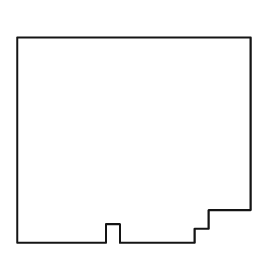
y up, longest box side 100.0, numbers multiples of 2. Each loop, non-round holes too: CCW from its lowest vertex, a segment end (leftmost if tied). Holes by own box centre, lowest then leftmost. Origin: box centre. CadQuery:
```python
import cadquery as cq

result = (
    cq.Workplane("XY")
    .moveTo(-50.0, -44.0)
    .lineTo(-12.0, -44.0)
    .lineTo(-12.0, -36.0)
    .lineTo(-6.0, -36.0)
    .lineTo(-6.0, -44.0)
    .lineTo(26.0, -44.0)
    .lineTo(26.0, -38.0)
    .lineTo(32.0, -38.0)
    .lineTo(32.0, -30.0)
    .lineTo(50.0, -30.0)
    .lineTo(50.0, 44.0)
    .lineTo(-50.0, 44.0)
    .close()
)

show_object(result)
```